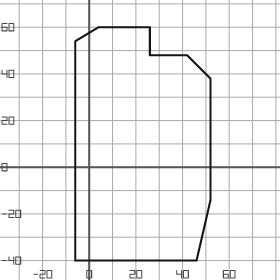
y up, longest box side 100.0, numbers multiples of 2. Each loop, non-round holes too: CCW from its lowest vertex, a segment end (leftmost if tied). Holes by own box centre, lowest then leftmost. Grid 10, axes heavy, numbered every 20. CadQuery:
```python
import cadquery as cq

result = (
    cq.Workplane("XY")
    .moveTo(-6.0, -40.0)
    .lineTo(46.0, -40.0)
    .lineTo(52.0, -14.0)
    .lineTo(52.0, 38.0)
    .lineTo(42.0, 48.0)
    .lineTo(26.0, 48.0)
    .lineTo(26.0, 60.0)
    .lineTo(4.0, 60.0)
    .lineTo(-6.0, 54.0)
    .close()
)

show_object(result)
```